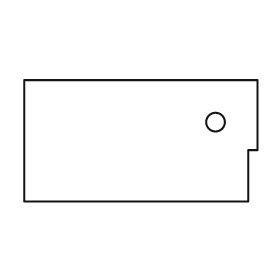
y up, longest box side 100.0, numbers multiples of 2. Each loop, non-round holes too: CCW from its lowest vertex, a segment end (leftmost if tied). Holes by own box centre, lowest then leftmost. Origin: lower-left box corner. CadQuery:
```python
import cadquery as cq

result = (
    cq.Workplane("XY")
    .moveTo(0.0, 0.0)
    .lineTo(96.0, 0.0)
    .lineTo(96.0, 22.0)
    .lineTo(100.0, 22.0)
    .lineTo(100.0, 52.0)
    .lineTo(0.0, 52.0)
    .close()
    .moveTo(82.0, 34.0)
    .circle(4.0)
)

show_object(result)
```